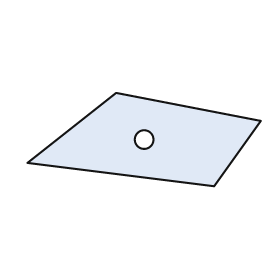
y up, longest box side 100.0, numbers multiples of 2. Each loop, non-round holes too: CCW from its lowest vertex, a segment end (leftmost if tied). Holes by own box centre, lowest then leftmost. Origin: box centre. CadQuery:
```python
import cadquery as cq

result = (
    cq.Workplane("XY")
    .moveTo(30.0, -20.0)
    .lineTo(50.0, 8.0)
    .lineTo(-12.0, 20.0)
    .lineTo(-50.0, -10.0)
    .close()
    .moveTo(0.0, 0.0)
    .circle(4.0)
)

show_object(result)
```